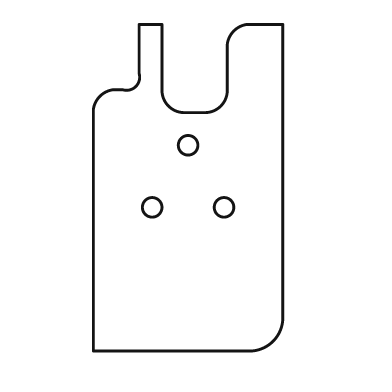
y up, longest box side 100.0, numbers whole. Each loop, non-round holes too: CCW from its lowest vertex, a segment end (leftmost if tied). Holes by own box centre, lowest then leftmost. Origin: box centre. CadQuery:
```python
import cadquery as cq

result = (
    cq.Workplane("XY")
    .moveTo(-29.0, -50.0)
    .lineTo(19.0, -50.0)
    .threePointArc((26.0, -47.0), (29.0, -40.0))
    .lineTo(29.0, 50.0)
    .lineTo(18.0, 50.0)
    .threePointArc((14.0, 48.0), (12.0, 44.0))
    .lineTo(12.0, 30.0)
    .threePointArc((10.0, 25.0), (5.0, 23.0))
    .lineTo(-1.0, 23.0)
    .threePointArc((-6.0, 25.0), (-8.0, 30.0))
    .lineTo(-8.0, 50.0)
    .lineTo(-15.0, 50.0)
    .lineTo(-15.0, 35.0)
    .threePointArc((-16.0, 31.0), (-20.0, 30.0))
    .lineTo(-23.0, 30.0)
    .threePointArc((-27.0, 28.0), (-29.0, 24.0))
    .close()
    .moveTo(-11.0, -6.0)
    .circle(3.0)
    .moveTo(11.0, -6.0)
    .circle(3.0)
    .moveTo(0.0, 13.0)
    .circle(3.0)
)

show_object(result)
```